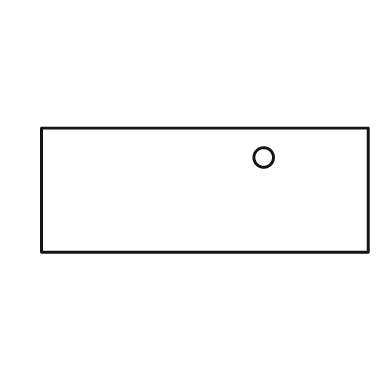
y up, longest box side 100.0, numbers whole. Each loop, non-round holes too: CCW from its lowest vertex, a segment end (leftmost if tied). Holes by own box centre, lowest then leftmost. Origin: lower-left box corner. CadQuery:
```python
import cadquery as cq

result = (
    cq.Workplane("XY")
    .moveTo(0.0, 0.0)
    .lineTo(100.0, 0.0)
    .lineTo(100.0, 38.0)
    .lineTo(0.0, 38.0)
    .close()
    .moveTo(68.0, 29.0)
    .circle(3.0)
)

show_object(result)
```